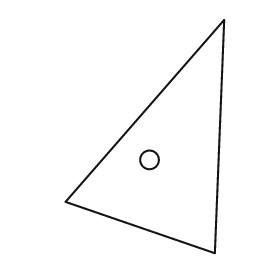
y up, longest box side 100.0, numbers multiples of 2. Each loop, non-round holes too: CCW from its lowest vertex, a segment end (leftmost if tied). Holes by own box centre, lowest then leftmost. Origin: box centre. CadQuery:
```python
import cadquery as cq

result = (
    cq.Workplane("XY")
    .moveTo(30.0, -50.0)
    .lineTo(34.0, 50.0)
    .lineTo(-34.0, -28.0)
    .close()
    .moveTo(2.0, -10.0)
    .circle(4.0)
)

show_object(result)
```